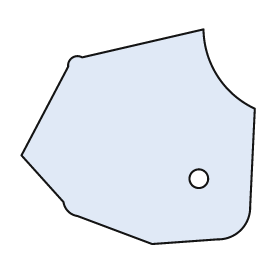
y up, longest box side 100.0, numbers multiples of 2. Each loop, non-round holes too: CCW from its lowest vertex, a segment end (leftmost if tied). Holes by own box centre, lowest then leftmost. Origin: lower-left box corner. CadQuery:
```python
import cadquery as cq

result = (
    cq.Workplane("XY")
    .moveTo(56.0, 0.0)
    .lineTo(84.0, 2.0)
    .threePointArc((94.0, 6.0), (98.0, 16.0))
    .lineTo(100.0, 58.0)
    .threePointArc((84.0, 72.0), (78.0, 92.0))
    .lineTo(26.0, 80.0)
    .threePointArc((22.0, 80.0), (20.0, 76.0))
    .lineTo(0.0, 38.0)
    .lineTo(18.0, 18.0)
    .threePointArc((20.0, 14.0), (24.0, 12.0))
    .close()
    .moveTo(76.0, 28.0)
    .circle(4.0)
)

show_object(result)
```